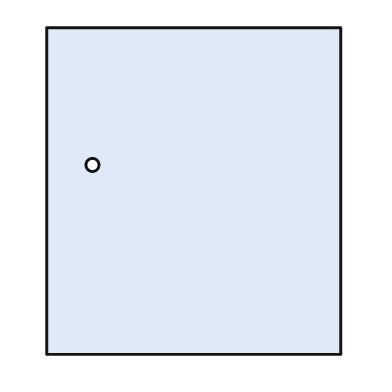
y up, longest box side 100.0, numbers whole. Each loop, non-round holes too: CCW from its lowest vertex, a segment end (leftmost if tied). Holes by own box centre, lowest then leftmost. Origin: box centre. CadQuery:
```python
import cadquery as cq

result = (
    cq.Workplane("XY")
    .moveTo(-45.0, -50.0)
    .lineTo(45.0, -50.0)
    .lineTo(45.0, 50.0)
    .lineTo(-45.0, 50.0)
    .close()
    .moveTo(-31.0, 8.0)
    .circle(2.0)
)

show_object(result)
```